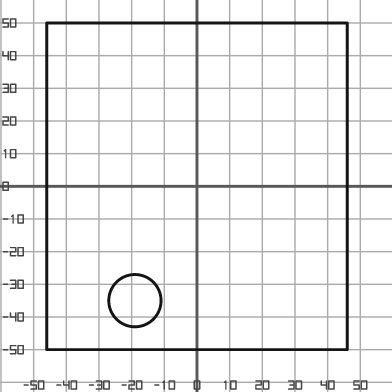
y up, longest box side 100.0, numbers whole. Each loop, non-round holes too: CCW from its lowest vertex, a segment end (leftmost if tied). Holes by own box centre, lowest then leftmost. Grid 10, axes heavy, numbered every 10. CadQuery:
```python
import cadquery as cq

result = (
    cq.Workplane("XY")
    .moveTo(-46.0, -50.0)
    .lineTo(46.0, -50.0)
    .lineTo(46.0, 50.0)
    .lineTo(-46.0, 50.0)
    .close()
    .moveTo(-19.0, -35.0)
    .circle(8.0)
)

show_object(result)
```